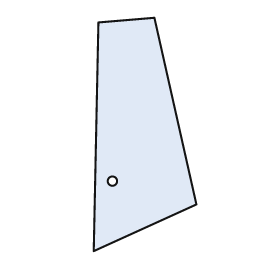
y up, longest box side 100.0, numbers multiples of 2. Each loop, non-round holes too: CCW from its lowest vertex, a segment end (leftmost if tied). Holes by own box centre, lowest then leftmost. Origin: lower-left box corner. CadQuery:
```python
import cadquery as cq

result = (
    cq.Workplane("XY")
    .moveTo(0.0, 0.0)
    .lineTo(44.0, 20.0)
    .lineTo(26.0, 100.0)
    .lineTo(2.0, 98.0)
    .close()
    .moveTo(8.0, 30.0)
    .circle(2.0)
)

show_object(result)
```